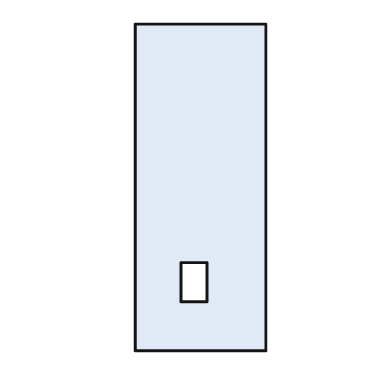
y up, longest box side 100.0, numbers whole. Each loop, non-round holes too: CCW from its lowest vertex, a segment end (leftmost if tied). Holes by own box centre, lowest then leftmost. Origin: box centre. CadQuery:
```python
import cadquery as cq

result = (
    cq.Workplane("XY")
    .moveTo(-20.0, -50.0)
    .lineTo(20.0, -50.0)
    .lineTo(20.0, 50.0)
    .lineTo(-20.0, 50.0)
    .close()
    .moveTo(-6.0, -35.0)
    .lineTo(2.0, -35.0)
    .lineTo(2.0, -23.0)
    .lineTo(-6.0, -23.0)
    .close()
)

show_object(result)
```